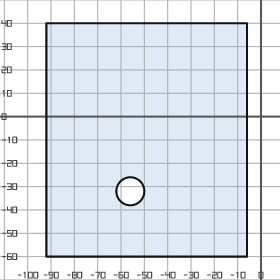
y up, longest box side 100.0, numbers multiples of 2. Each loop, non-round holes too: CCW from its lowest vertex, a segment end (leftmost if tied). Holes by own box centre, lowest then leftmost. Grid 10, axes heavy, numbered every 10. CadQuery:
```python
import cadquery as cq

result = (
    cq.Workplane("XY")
    .moveTo(-92.0, -60.0)
    .lineTo(-6.0, -60.0)
    .lineTo(-6.0, 40.0)
    .lineTo(-92.0, 40.0)
    .close()
    .moveTo(-56.0, -32.0)
    .circle(6.0)
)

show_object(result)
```